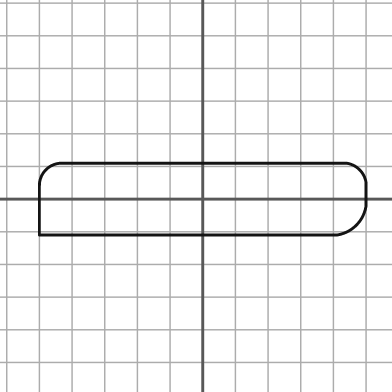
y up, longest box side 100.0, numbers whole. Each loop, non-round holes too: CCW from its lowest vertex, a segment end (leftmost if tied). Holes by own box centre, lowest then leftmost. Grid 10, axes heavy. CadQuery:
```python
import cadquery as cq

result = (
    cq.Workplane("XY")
    .moveTo(-50.0, -11.0)
    .lineTo(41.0, -11.0)
    .threePointArc((47.0, -8.0), (50.0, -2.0))
    .lineTo(50.0, 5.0)
    .threePointArc((48.0, 9.0), (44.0, 11.0))
    .lineTo(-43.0, 11.0)
    .threePointArc((-48.0, 9.0), (-50.0, 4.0))
    .close()
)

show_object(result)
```